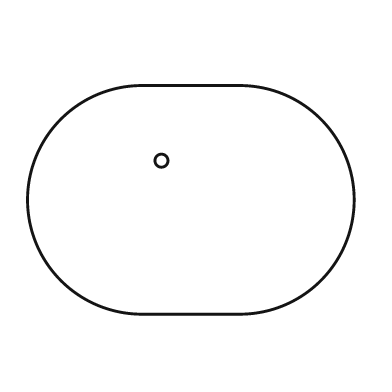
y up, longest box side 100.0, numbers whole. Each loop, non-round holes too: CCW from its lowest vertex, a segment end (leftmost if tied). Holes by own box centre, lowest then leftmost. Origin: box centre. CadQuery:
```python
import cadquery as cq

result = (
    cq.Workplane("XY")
    .moveTo(-15.0, -35.0)
    .lineTo(15.0, -35.0)
    .threePointArc((50.0, 0.0), (15.0, 35.0))
    .lineTo(-15.0, 35.0)
    .threePointArc((-50.0, 0.0), (-15.0, -35.0))
    .close()
    .moveTo(-9.0, 12.0)
    .circle(2.0)
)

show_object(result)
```